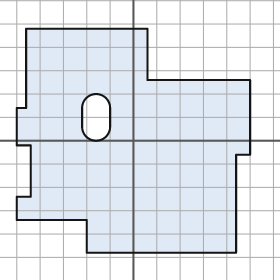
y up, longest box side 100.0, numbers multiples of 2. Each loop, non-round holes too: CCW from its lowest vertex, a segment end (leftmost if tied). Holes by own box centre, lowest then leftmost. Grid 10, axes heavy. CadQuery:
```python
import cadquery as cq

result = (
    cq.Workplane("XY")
    .moveTo(-20.0, -48.0)
    .lineTo(44.0, -48.0)
    .lineTo(44.0, -6.0)
    .lineTo(50.0, -6.0)
    .lineTo(50.0, 26.0)
    .lineTo(6.0, 26.0)
    .lineTo(6.0, 48.0)
    .lineTo(-46.0, 48.0)
    .lineTo(-46.0, 14.0)
    .lineTo(-50.0, 14.0)
    .lineTo(-50.0, -2.0)
    .lineTo(-44.0, -2.0)
    .lineTo(-44.0, -24.0)
    .lineTo(-50.0, -24.0)
    .lineTo(-50.0, -34.0)
    .lineTo(-20.0, -34.0)
    .close()
    .moveTo(-22.0, 6.0)
    .threePointArc((-16.0, 0.0), (-10.0, 6.0))
    .lineTo(-10.0, 14.0)
    .threePointArc((-16.0, 20.0), (-22.0, 14.0))
    .close()
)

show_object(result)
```